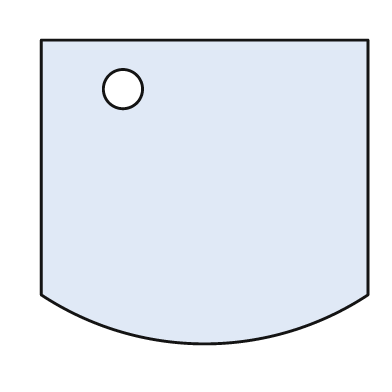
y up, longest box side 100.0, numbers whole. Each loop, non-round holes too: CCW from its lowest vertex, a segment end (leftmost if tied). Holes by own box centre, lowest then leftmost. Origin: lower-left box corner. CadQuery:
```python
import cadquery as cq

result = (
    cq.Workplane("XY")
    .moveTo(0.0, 15.0)
    .threePointArc((50.0, 0.0), (100.0, 15.0))
    .lineTo(100.0, 93.0)
    .lineTo(0.0, 93.0)
    .close()
    .moveTo(25.0, 78.0)
    .circle(6.0)
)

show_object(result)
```